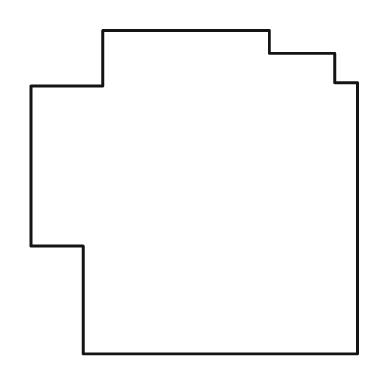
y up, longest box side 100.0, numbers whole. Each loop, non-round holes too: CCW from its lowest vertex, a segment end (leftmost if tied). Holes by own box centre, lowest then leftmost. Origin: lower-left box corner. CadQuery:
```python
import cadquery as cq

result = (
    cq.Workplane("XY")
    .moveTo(16.0, 0.0)
    .lineTo(100.0, 0.0)
    .lineTo(100.0, 83.0)
    .lineTo(93.0, 83.0)
    .lineTo(93.0, 92.0)
    .lineTo(73.0, 92.0)
    .lineTo(73.0, 99.0)
    .lineTo(22.0, 99.0)
    .lineTo(22.0, 82.0)
    .lineTo(0.0, 82.0)
    .lineTo(0.0, 33.0)
    .lineTo(16.0, 33.0)
    .close()
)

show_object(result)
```